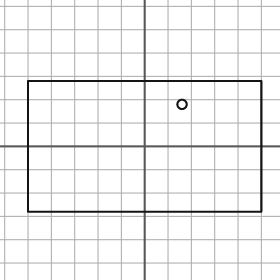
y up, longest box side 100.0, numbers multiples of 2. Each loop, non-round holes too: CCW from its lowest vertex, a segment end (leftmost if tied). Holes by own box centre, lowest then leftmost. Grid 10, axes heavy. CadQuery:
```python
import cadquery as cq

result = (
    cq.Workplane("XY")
    .moveTo(-50.0, -28.0)
    .lineTo(50.0, -28.0)
    .lineTo(50.0, 28.0)
    .lineTo(-50.0, 28.0)
    .close()
    .moveTo(16.0, 18.0)
    .circle(2.0)
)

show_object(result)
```